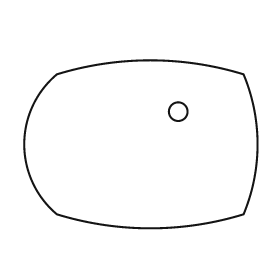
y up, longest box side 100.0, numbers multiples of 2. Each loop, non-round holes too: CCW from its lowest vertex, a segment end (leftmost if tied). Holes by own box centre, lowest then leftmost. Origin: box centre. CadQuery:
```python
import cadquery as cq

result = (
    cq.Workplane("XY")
    .moveTo(-36.0, -30.0)
    .threePointArc((4.0, -36.0), (44.0, -30.0))
    .threePointArc((50.0, 0.0), (44.0, 30.0))
    .threePointArc((4.0, 36.0), (-36.0, 30.0))
    .threePointArc((-50.0, 0.0), (-36.0, -30.0))
    .close()
    .moveTo(16.0, 14.0)
    .circle(4.0)
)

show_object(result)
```